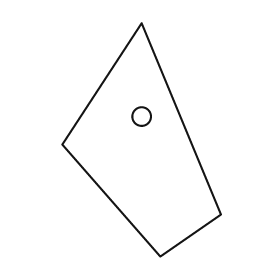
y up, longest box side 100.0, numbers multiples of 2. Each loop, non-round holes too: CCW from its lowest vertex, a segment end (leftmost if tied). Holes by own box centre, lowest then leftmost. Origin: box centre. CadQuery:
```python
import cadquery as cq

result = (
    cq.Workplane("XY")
    .moveTo(8.0, -50.0)
    .lineTo(34.0, -32.0)
    .lineTo(0.0, 50.0)
    .lineTo(-34.0, -2.0)
    .close()
    .moveTo(0.0, 10.0)
    .circle(4.0)
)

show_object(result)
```